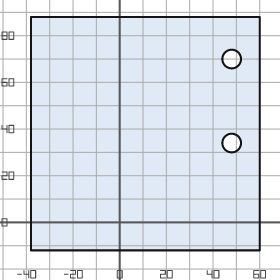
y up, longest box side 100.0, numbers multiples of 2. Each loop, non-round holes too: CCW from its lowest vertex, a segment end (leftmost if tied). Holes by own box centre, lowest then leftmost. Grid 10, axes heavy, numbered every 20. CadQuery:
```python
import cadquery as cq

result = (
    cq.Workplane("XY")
    .moveTo(-38.0, -12.0)
    .lineTo(60.0, -12.0)
    .lineTo(60.0, 88.0)
    .lineTo(-38.0, 88.0)
    .close()
    .moveTo(48.0, 34.0)
    .circle(4.0)
    .moveTo(48.0, 70.0)
    .circle(4.0)
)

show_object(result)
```